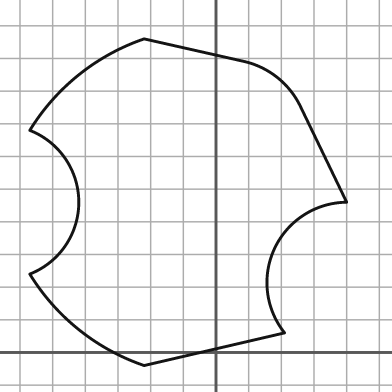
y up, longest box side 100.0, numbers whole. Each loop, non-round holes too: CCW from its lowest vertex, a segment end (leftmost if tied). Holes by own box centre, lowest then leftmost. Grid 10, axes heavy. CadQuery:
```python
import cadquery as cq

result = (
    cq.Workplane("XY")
    .moveTo(-22.0, -4.0)
    .lineTo(21.0, 6.0)
    .threePointArc((18.0, 32.0), (40.0, 46.0))
    .lineTo(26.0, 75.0)
    .threePointArc((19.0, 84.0), (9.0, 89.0))
    .lineTo(-22.0, 96.0)
    .threePointArc((-42.0, 85.0), (-57.0, 68.0))
    .threePointArc((-42.0, 46.0), (-57.0, 24.0))
    .threePointArc((-42.0, 7.0), (-22.0, -4.0))
    .close()
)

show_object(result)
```